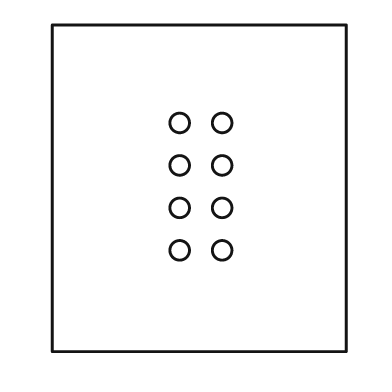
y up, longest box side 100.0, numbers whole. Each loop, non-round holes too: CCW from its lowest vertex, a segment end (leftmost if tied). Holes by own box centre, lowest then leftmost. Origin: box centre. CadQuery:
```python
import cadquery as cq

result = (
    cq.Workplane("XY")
    .moveTo(-45.0, -50.0)
    .lineTo(45.0, -50.0)
    .lineTo(45.0, 50.0)
    .lineTo(-45.0, 50.0)
    .close()
    .moveTo(-6.0, -19.0)
    .circle(3.0)
    .moveTo(7.0, -19.0)
    .circle(3.0)
    .moveTo(-6.0, -6.0)
    .circle(3.0)
    .moveTo(7.0, -6.0)
    .circle(3.0)
    .moveTo(-6.0, 7.0)
    .circle(3.0)
    .moveTo(7.0, 7.0)
    .circle(3.0)
    .moveTo(-6.0, 20.0)
    .circle(3.0)
    .moveTo(7.0, 20.0)
    .circle(3.0)
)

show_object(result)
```